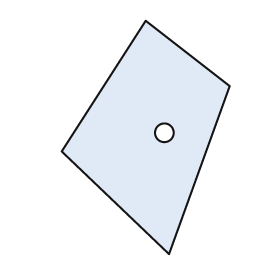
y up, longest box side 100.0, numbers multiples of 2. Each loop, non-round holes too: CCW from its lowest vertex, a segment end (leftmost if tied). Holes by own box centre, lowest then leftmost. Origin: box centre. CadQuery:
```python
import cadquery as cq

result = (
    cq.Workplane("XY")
    .moveTo(10.0, -50.0)
    .lineTo(36.0, 22.0)
    .lineTo(0.0, 50.0)
    .lineTo(-36.0, -6.0)
    .close()
    .moveTo(8.0, 2.0)
    .circle(4.0)
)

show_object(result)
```